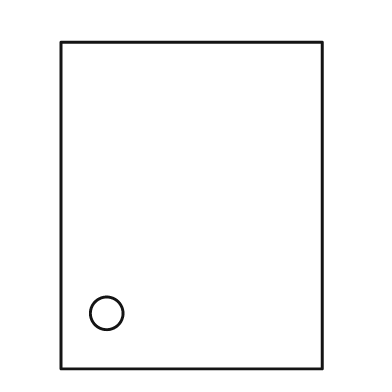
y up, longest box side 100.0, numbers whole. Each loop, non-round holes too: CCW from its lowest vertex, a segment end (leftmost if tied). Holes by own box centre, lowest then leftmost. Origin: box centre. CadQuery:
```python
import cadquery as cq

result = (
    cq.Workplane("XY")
    .moveTo(-40.0, -50.0)
    .lineTo(40.0, -50.0)
    .lineTo(40.0, 50.0)
    .lineTo(-40.0, 50.0)
    .close()
    .moveTo(-26.0, -33.0)
    .circle(5.0)
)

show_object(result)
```